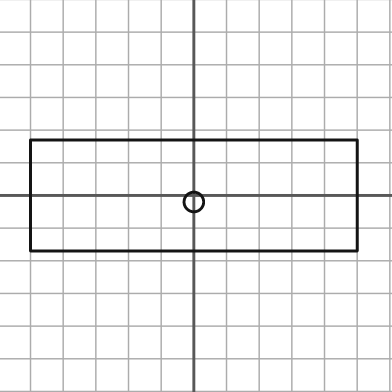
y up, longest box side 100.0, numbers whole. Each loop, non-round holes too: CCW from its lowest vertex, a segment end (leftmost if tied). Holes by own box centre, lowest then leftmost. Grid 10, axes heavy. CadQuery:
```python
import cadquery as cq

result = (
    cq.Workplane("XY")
    .moveTo(-50.0, -17.0)
    .lineTo(50.0, -17.0)
    .lineTo(50.0, 17.0)
    .lineTo(-50.0, 17.0)
    .close()
    .moveTo(0.0, -2.0)
    .circle(3.0)
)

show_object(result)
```